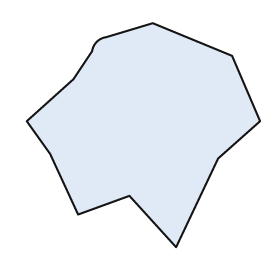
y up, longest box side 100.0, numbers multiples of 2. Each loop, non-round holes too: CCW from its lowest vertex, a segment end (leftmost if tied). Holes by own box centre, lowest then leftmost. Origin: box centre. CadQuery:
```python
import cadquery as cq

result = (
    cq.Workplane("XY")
    .moveTo(14.0, -48.0)
    .lineTo(32.0, -10.0)
    .lineTo(50.0, 6.0)
    .lineTo(38.0, 34.0)
    .lineTo(4.0, 48.0)
    .lineTo(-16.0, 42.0)
    .threePointArc((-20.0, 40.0), (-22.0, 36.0))
    .lineTo(-30.0, 24.0)
    .lineTo(-50.0, 6.0)
    .lineTo(-40.0, -8.0)
    .lineTo(-28.0, -34.0)
    .lineTo(-6.0, -26.0)
    .close()
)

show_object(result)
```